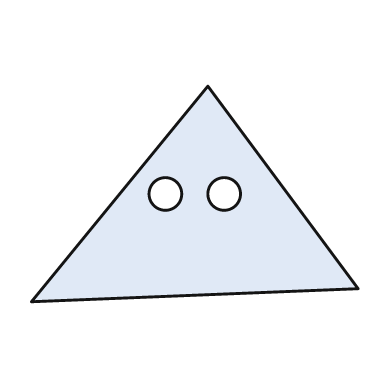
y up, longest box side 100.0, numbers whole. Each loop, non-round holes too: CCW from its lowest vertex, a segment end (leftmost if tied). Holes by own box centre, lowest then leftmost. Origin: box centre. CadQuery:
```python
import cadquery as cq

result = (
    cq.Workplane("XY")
    .moveTo(-50.0, -33.0)
    .lineTo(50.0, -29.0)
    .lineTo(4.0, 33.0)
    .close()
    .moveTo(-9.0, 0.0)
    .circle(5.0)
    .moveTo(9.0, 0.0)
    .circle(5.0)
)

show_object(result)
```